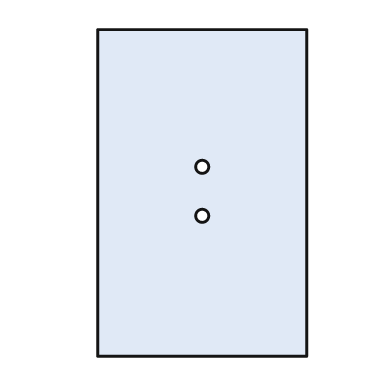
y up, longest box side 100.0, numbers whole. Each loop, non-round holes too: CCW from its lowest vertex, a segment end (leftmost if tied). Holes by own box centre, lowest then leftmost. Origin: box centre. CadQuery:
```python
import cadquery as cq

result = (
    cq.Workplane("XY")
    .moveTo(-32.0, -50.0)
    .lineTo(32.0, -50.0)
    .lineTo(32.0, 50.0)
    .lineTo(-32.0, 50.0)
    .close()
    .moveTo(0.0, -7.0)
    .circle(2.0)
    .moveTo(0.0, 8.0)
    .circle(2.0)
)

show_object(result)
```